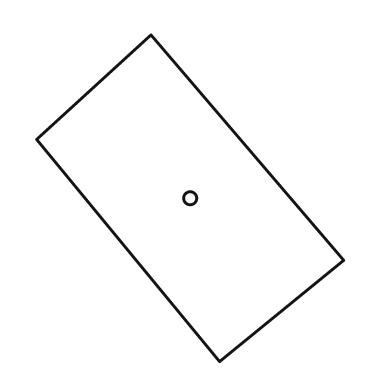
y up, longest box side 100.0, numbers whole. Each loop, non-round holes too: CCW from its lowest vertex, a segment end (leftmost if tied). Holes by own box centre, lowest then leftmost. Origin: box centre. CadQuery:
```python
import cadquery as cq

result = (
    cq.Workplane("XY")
    .moveTo(9.0, -50.0)
    .lineTo(47.0, -19.0)
    .lineTo(-12.0, 50.0)
    .lineTo(-47.0, 18.0)
    .close()
    .moveTo(0.0, 0.0)
    .circle(2.0)
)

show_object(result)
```